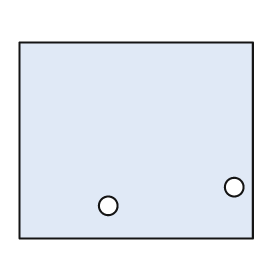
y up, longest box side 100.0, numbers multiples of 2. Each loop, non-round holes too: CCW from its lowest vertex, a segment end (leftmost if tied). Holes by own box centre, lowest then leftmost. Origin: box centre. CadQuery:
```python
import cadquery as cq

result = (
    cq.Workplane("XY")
    .moveTo(-50.0, -42.0)
    .lineTo(50.0, -42.0)
    .lineTo(50.0, 42.0)
    .lineTo(-50.0, 42.0)
    .close()
    .moveTo(-12.0, -28.0)
    .circle(4.0)
    .moveTo(42.0, -20.0)
    .circle(4.0)
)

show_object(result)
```